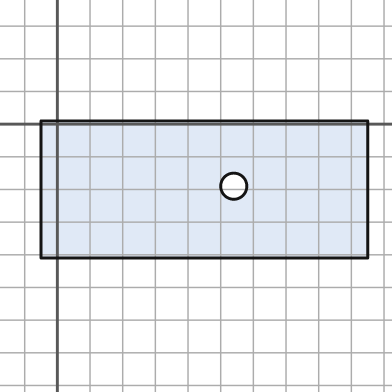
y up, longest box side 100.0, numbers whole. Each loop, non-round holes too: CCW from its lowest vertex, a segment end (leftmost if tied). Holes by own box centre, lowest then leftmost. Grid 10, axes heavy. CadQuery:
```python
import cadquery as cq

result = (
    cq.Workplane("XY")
    .moveTo(-5.0, -41.0)
    .lineTo(95.0, -41.0)
    .lineTo(95.0, 1.0)
    .lineTo(-5.0, 1.0)
    .close()
    .moveTo(54.0, -19.0)
    .circle(4.0)
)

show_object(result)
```